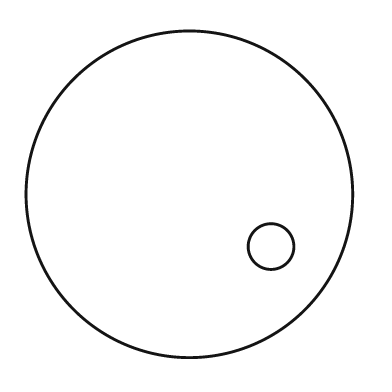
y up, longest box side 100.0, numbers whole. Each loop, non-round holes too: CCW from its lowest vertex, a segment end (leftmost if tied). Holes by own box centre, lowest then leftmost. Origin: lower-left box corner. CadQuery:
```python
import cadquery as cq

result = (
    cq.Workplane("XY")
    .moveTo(50.0, 50.0)
    .circle(50.0)
    .moveTo(75.0, 34.0)
    .circle(7.0)
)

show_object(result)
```